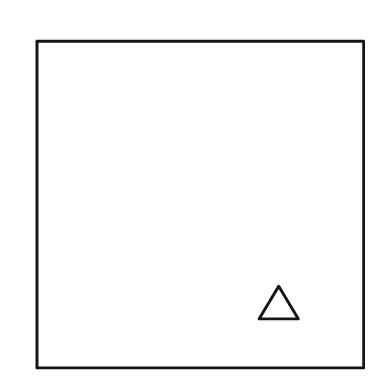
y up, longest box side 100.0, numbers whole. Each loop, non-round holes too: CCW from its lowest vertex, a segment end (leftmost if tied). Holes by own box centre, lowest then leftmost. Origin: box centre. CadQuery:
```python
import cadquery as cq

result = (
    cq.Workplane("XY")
    .moveTo(-50.0, -50.0)
    .lineTo(50.0, -50.0)
    .lineTo(50.0, 50.0)
    .lineTo(-50.0, 50.0)
    .close()
    .moveTo(18.0, -35.0)
    .lineTo(30.0, -35.0)
    .lineTo(24.0, -25.0)
    .close()
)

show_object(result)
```